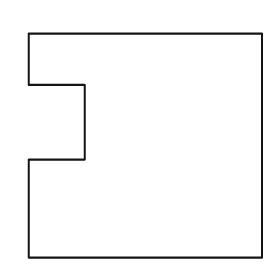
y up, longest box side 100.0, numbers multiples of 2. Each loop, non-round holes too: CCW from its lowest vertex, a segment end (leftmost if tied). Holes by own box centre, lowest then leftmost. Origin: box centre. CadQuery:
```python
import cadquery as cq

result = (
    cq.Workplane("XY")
    .moveTo(-50.0, -48.0)
    .lineTo(50.0, -48.0)
    .lineTo(50.0, 48.0)
    .lineTo(-50.0, 48.0)
    .lineTo(-50.0, 26.0)
    .lineTo(-26.0, 26.0)
    .lineTo(-26.0, -6.0)
    .lineTo(-50.0, -6.0)
    .close()
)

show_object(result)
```